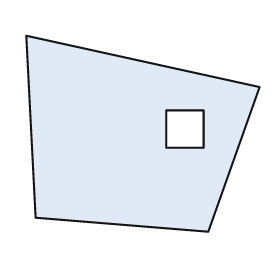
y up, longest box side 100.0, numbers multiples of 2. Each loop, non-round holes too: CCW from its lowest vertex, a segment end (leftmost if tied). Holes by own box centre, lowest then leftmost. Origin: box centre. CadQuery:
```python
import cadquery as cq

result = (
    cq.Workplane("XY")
    .moveTo(28.0, -42.0)
    .lineTo(50.0, 20.0)
    .lineTo(-50.0, 42.0)
    .lineTo(-46.0, -36.0)
    .close()
    .moveTo(10.0, -6.0)
    .lineTo(26.0, -6.0)
    .lineTo(26.0, 10.0)
    .lineTo(10.0, 10.0)
    .close()
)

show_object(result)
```